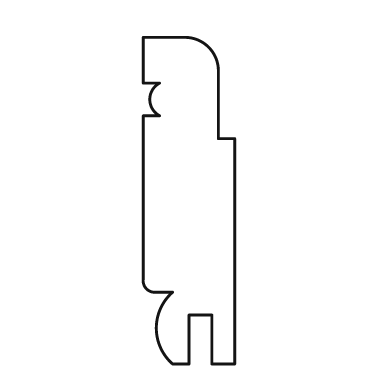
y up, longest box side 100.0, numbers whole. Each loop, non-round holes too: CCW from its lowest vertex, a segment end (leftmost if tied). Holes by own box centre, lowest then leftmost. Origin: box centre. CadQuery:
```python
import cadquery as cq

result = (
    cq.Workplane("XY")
    .moveTo(-5.0, -50.0)
    .lineTo(0.0, -50.0)
    .lineTo(0.0, -35.0)
    .lineTo(7.0, -35.0)
    .lineTo(7.0, -50.0)
    .lineTo(14.0, -50.0)
    .lineTo(14.0, 19.0)
    .lineTo(9.0, 19.0)
    .lineTo(9.0, 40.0)
    .threePointArc((6.0, 47.0), (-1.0, 50.0))
    .lineTo(-14.0, 50.0)
    .lineTo(-14.0, 36.0)
    .lineTo(-9.0, 36.0)
    .threePointArc((-12.0, 31.0), (-9.0, 26.0))
    .lineTo(-14.0, 26.0)
    .lineTo(-14.0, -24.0)
    .threePointArc((-13.0, -27.0), (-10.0, -28.0))
    .lineTo(-5.0, -28.0)
    .threePointArc((-10.0, -39.0), (-5.0, -50.0))
    .close()
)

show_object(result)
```